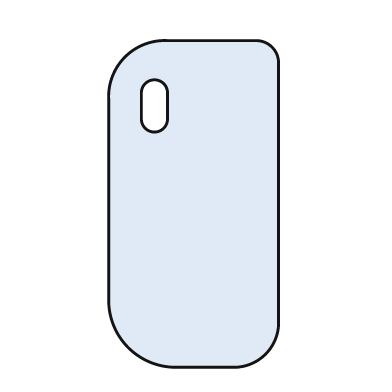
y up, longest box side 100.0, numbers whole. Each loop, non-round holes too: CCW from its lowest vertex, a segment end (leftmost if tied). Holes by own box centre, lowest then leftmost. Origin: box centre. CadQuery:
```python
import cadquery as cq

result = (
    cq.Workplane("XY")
    .moveTo(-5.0, -50.0)
    .lineTo(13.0, -50.0)
    .threePointArc((22.0, -46.0), (26.0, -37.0))
    .lineTo(26.0, 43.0)
    .threePointArc((24.0, 48.0), (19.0, 50.0))
    .lineTo(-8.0, 50.0)
    .threePointArc((-21.0, 45.0), (-26.0, 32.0))
    .lineTo(-26.0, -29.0)
    .threePointArc((-20.0, -44.0), (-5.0, -50.0))
    .close()
    .moveTo(-16.0, 26.0)
    .threePointArc((-12.0, 22.0), (-8.0, 26.0))
    .lineTo(-8.0, 34.0)
    .threePointArc((-12.0, 38.0), (-16.0, 34.0))
    .close()
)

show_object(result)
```